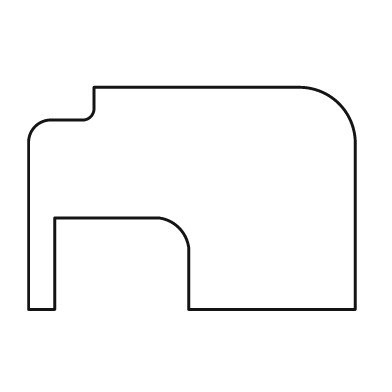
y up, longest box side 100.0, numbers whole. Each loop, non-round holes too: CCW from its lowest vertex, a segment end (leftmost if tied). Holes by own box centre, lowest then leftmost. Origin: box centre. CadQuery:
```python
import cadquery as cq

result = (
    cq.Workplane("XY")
    .moveTo(-50.0, -34.0)
    .lineTo(-42.0, -34.0)
    .lineTo(-42.0, -6.0)
    .lineTo(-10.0, -6.0)
    .threePointArc((-4.0, -9.0), (-1.0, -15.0))
    .lineTo(-1.0, -34.0)
    .lineTo(50.0, -34.0)
    .lineTo(50.0, 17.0)
    .threePointArc((45.0, 29.0), (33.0, 34.0))
    .lineTo(-30.0, 34.0)
    .lineTo(-30.0, 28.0)
    .threePointArc((-31.0, 25.0), (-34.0, 24.0))
    .lineTo(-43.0, 24.0)
    .threePointArc((-48.0, 22.0), (-50.0, 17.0))
    .close()
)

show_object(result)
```